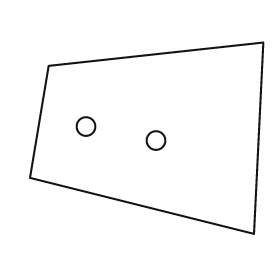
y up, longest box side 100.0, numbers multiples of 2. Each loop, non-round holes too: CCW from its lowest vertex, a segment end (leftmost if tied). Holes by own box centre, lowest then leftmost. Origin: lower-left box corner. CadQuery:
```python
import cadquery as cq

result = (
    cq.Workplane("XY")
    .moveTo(96.0, 0.0)
    .lineTo(100.0, 82.0)
    .lineTo(8.0, 72.0)
    .lineTo(0.0, 24.0)
    .close()
    .moveTo(54.0, 40.0)
    .circle(4.0)
    .moveTo(24.0, 46.0)
    .circle(4.0)
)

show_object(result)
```